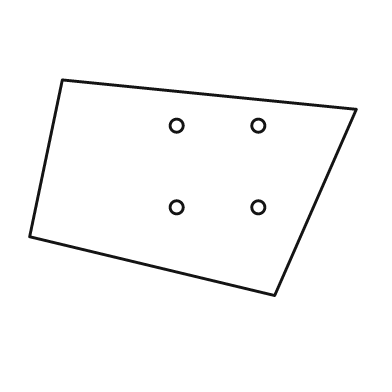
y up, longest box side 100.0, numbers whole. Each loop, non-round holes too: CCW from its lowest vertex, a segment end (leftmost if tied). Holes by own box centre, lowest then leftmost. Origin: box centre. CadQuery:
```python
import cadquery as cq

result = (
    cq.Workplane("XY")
    .moveTo(25.0, -33.0)
    .lineTo(50.0, 24.0)
    .lineTo(-40.0, 33.0)
    .lineTo(-50.0, -15.0)
    .close()
    .moveTo(-5.0, -6.0)
    .circle(2.0)
    .moveTo(20.0, -6.0)
    .circle(2.0)
    .moveTo(-5.0, 19.0)
    .circle(2.0)
    .moveTo(20.0, 19.0)
    .circle(2.0)
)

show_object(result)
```